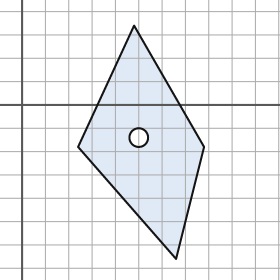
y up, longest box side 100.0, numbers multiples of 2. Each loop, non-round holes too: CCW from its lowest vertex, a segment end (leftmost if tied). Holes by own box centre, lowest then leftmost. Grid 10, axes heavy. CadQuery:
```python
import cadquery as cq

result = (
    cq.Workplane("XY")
    .moveTo(66.0, -66.0)
    .lineTo(78.0, -18.0)
    .lineTo(48.0, 34.0)
    .lineTo(24.0, -18.0)
    .close()
    .moveTo(50.0, -14.0)
    .circle(4.0)
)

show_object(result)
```